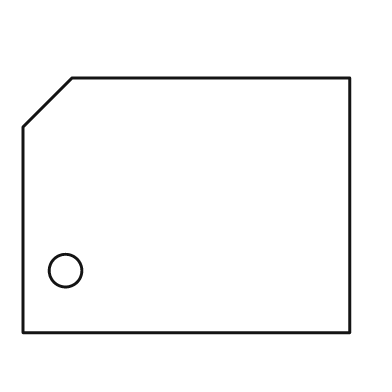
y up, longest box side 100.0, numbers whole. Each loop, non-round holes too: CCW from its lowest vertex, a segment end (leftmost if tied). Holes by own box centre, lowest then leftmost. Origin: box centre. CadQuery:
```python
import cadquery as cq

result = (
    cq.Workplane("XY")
    .moveTo(-50.0, -39.0)
    .lineTo(50.0, -39.0)
    .lineTo(50.0, 39.0)
    .lineTo(-35.0, 39.0)
    .lineTo(-50.0, 24.0)
    .close()
    .moveTo(-37.0, -20.0)
    .circle(5.0)
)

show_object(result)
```